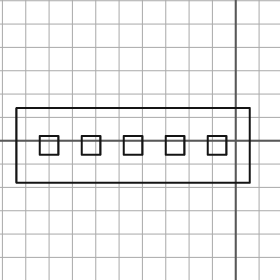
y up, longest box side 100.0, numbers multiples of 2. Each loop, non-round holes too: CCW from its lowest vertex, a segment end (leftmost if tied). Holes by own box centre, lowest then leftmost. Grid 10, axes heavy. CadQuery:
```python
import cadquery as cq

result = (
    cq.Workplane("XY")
    .moveTo(-94.0, -18.0)
    .lineTo(6.0, -18.0)
    .lineTo(6.0, 14.0)
    .lineTo(-94.0, 14.0)
    .close()
    .moveTo(-84.0, -6.0)
    .lineTo(-76.0, -6.0)
    .lineTo(-76.0, 2.0)
    .lineTo(-84.0, 2.0)
    .close()
    .moveTo(-66.0, -6.0)
    .lineTo(-58.0, -6.0)
    .lineTo(-58.0, 2.0)
    .lineTo(-66.0, 2.0)
    .close()
    .moveTo(-48.0, -6.0)
    .lineTo(-40.0, -6.0)
    .lineTo(-40.0, 2.0)
    .lineTo(-48.0, 2.0)
    .close()
    .moveTo(-30.0, -6.0)
    .lineTo(-22.0, -6.0)
    .lineTo(-22.0, 2.0)
    .lineTo(-30.0, 2.0)
    .close()
    .moveTo(-12.0, -6.0)
    .lineTo(-4.0, -6.0)
    .lineTo(-4.0, 2.0)
    .lineTo(-12.0, 2.0)
    .close()
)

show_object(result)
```